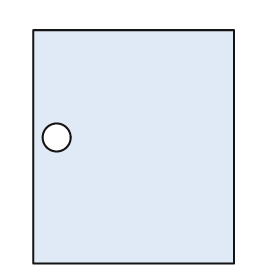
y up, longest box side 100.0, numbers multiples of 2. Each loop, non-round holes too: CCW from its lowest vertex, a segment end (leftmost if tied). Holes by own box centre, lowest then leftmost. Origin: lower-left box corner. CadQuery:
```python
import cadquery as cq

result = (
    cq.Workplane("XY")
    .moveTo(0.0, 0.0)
    .lineTo(86.0, 0.0)
    .lineTo(86.0, 100.0)
    .lineTo(0.0, 100.0)
    .close()
    .moveTo(10.0, 54.0)
    .circle(6.0)
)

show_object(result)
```